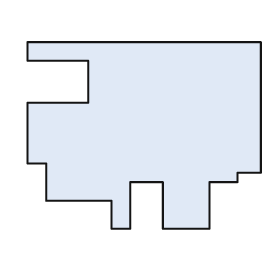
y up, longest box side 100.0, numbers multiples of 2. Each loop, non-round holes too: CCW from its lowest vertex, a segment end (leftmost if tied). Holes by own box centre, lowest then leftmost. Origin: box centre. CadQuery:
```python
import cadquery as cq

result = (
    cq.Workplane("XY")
    .moveTo(-14.0, -40.0)
    .lineTo(-6.0, -40.0)
    .lineTo(-6.0, -20.0)
    .lineTo(8.0, -20.0)
    .lineTo(8.0, -40.0)
    .lineTo(28.0, -40.0)
    .lineTo(28.0, -20.0)
    .lineTo(40.0, -20.0)
    .lineTo(40.0, -16.0)
    .lineTo(50.0, -16.0)
    .lineTo(50.0, 40.0)
    .lineTo(-50.0, 40.0)
    .lineTo(-50.0, 32.0)
    .lineTo(-24.0, 32.0)
    .lineTo(-24.0, 14.0)
    .lineTo(-50.0, 14.0)
    .lineTo(-50.0, -12.0)
    .lineTo(-42.0, -12.0)
    .lineTo(-42.0, -28.0)
    .lineTo(-14.0, -28.0)
    .close()
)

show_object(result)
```